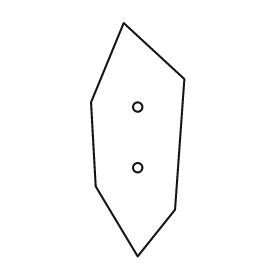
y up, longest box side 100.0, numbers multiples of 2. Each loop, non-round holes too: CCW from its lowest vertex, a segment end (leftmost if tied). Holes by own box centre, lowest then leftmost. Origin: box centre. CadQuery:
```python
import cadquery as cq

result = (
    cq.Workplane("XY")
    .moveTo(0.0, -50.0)
    .lineTo(16.0, -30.0)
    .lineTo(20.0, 26.0)
    .lineTo(-6.0, 50.0)
    .lineTo(-20.0, 16.0)
    .lineTo(-18.0, -20.0)
    .close()
    .moveTo(0.0, -12.0)
    .circle(2.0)
    .moveTo(0.0, 14.0)
    .circle(2.0)
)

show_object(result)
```